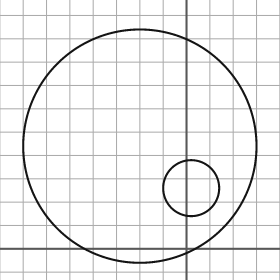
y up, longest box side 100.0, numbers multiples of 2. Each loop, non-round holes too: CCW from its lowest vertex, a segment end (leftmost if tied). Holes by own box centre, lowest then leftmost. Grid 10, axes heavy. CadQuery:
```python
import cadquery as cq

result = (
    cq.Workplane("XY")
    .moveTo(-20.0, 44.0)
    .circle(50.0)
    .moveTo(2.0, 26.0)
    .circle(12.0)
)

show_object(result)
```